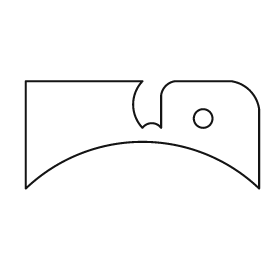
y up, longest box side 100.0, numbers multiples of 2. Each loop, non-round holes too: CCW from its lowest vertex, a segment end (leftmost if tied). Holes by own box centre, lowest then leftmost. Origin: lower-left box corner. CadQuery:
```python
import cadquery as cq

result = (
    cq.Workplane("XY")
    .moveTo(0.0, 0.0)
    .threePointArc((50.0, 20.0), (100.0, 0.0))
    .lineTo(100.0, 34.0)
    .threePointArc((96.0, 42.0), (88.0, 46.0))
    .lineTo(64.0, 46.0)
    .threePointArc((60.0, 44.0), (58.0, 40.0))
    .lineTo(58.0, 26.0)
    .threePointArc((54.0, 28.0), (50.0, 26.0))
    .threePointArc((46.0, 36.0), (50.0, 46.0))
    .lineTo(0.0, 46.0)
    .close()
    .moveTo(76.0, 30.0)
    .circle(4.0)
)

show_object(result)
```